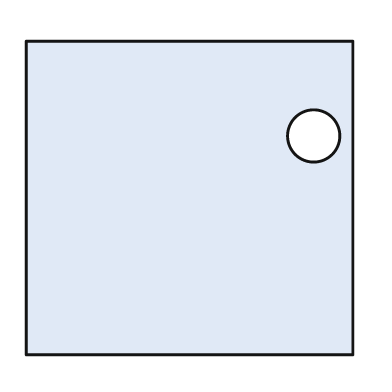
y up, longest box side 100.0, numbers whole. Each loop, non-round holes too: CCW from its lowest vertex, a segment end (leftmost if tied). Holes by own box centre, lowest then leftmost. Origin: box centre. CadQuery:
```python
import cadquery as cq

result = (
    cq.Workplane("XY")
    .moveTo(-50.0, -48.0)
    .lineTo(50.0, -48.0)
    .lineTo(50.0, 48.0)
    .lineTo(-50.0, 48.0)
    .close()
    .moveTo(38.0, 19.0)
    .circle(8.0)
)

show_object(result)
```